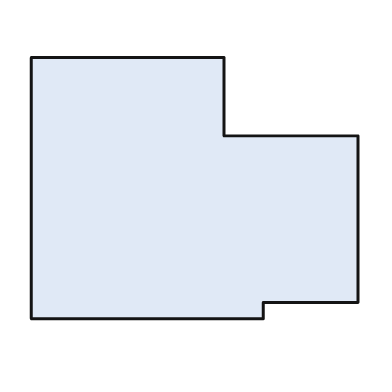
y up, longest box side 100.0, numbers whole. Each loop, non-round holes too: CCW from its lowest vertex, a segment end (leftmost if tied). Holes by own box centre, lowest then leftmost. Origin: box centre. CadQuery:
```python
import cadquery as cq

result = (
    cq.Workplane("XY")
    .moveTo(-50.0, -40.0)
    .lineTo(21.0, -40.0)
    .lineTo(21.0, -35.0)
    .lineTo(50.0, -35.0)
    .lineTo(50.0, 16.0)
    .lineTo(9.0, 16.0)
    .lineTo(9.0, 40.0)
    .lineTo(-50.0, 40.0)
    .close()
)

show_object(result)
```